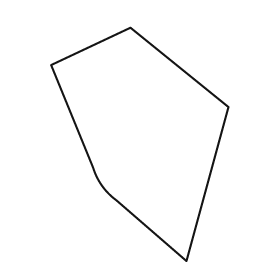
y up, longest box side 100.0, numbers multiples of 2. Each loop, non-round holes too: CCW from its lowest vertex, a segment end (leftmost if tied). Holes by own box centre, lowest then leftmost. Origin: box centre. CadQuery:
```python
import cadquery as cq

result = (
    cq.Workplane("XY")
    .moveTo(20.0, -50.0)
    .lineTo(38.0, 16.0)
    .lineTo(-4.0, 50.0)
    .lineTo(-38.0, 34.0)
    .lineTo(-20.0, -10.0)
    .threePointArc((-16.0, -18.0), (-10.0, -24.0))
    .close()
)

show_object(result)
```